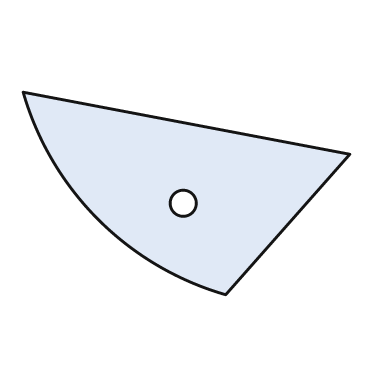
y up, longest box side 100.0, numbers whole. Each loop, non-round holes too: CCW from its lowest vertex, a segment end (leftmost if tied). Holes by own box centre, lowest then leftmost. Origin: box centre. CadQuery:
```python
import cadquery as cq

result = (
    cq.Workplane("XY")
    .moveTo(12.0, -31.0)
    .lineTo(50.0, 12.0)
    .lineTo(-50.0, 31.0)
    .threePointArc((-27.0, -8.0), (12.0, -31.0))
    .close()
    .moveTo(-1.0, -3.0)
    .circle(4.0)
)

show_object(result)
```